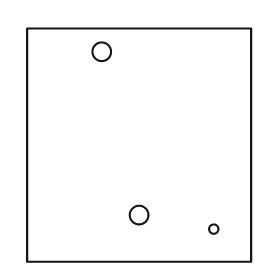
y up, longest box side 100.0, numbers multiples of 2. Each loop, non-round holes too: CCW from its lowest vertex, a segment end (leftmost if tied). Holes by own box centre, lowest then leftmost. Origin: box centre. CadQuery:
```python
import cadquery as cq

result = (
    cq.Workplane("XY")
    .moveTo(-48.0, -50.0)
    .lineTo(48.0, -50.0)
    .lineTo(48.0, 50.0)
    .lineTo(-48.0, 50.0)
    .close()
    .moveTo(32.0, -36.0)
    .circle(2.0)
    .moveTo(0.0, -30.0)
    .circle(4.0)
    .moveTo(-16.0, 40.0)
    .circle(4.0)
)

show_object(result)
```